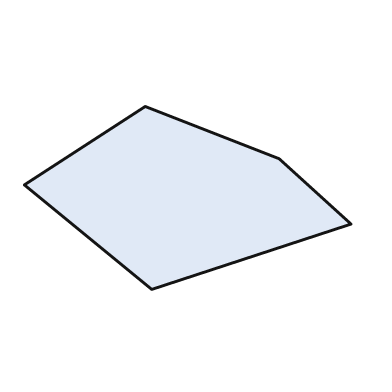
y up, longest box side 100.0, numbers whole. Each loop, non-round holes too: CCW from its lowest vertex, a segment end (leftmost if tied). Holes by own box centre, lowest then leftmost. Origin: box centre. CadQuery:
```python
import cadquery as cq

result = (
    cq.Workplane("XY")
    .moveTo(-11.0, -28.0)
    .lineTo(50.0, -8.0)
    .lineTo(28.0, 12.0)
    .lineTo(-13.0, 28.0)
    .lineTo(-50.0, 4.0)
    .close()
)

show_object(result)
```